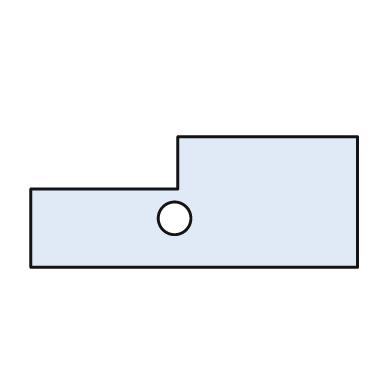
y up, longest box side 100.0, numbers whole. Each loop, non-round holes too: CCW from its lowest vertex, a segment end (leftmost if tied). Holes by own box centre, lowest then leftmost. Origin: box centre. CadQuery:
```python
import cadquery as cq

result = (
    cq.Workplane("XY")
    .moveTo(-50.0, -20.0)
    .lineTo(50.0, -20.0)
    .lineTo(50.0, 20.0)
    .lineTo(-5.0, 20.0)
    .lineTo(-5.0, 4.0)
    .lineTo(-50.0, 4.0)
    .close()
    .moveTo(-6.0, -5.0)
    .circle(5.0)
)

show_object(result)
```